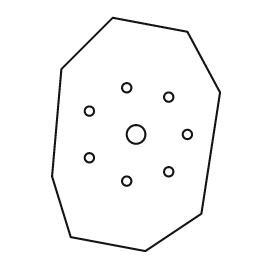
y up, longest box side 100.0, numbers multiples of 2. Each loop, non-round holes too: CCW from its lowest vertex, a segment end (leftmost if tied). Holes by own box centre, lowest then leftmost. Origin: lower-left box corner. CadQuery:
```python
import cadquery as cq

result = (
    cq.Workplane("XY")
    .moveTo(40.0, 0.0)
    .lineTo(64.0, 16.0)
    .lineTo(72.0, 68.0)
    .lineTo(58.0, 94.0)
    .lineTo(26.0, 100.0)
    .lineTo(4.0, 78.0)
    .lineTo(0.0, 32.0)
    .lineTo(8.0, 6.0)
    .close()
    .moveTo(32.0, 30.0)
    .circle(2.0)
    .moveTo(50.0, 34.0)
    .circle(2.0)
    .moveTo(16.0, 40.0)
    .circle(2.0)
    .moveTo(36.0, 50.0)
    .circle(4.0)
    .moveTo(58.0, 50.0)
    .circle(2.0)
    .moveTo(16.0, 60.0)
    .circle(2.0)
    .moveTo(50.0, 66.0)
    .circle(2.0)
    .moveTo(32.0, 70.0)
    .circle(2.0)
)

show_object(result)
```